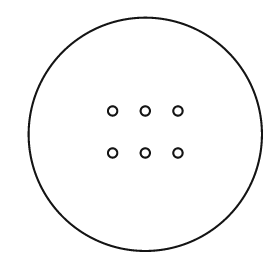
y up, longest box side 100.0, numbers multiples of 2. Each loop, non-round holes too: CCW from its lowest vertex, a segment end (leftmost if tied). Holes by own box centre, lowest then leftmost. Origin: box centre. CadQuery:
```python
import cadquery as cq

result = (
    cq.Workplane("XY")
    .moveTo(0.0, 0.0)
    .circle(50.0)
    .moveTo(-14.0, -8.0)
    .circle(2.0)
    .moveTo(0.0, -8.0)
    .circle(2.0)
    .moveTo(14.0, -8.0)
    .circle(2.0)
    .moveTo(-14.0, 10.0)
    .circle(2.0)
    .moveTo(0.0, 10.0)
    .circle(2.0)
    .moveTo(14.0, 10.0)
    .circle(2.0)
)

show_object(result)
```